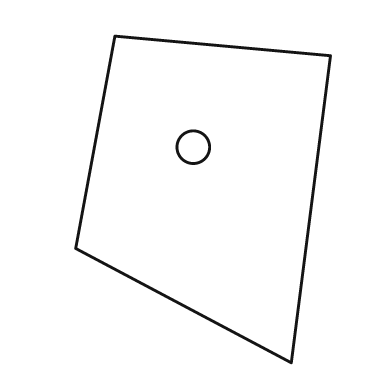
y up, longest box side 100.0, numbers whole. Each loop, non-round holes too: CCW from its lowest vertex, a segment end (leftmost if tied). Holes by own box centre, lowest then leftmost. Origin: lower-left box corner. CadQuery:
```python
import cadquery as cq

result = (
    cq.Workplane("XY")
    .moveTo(66.0, 0.0)
    .lineTo(78.0, 94.0)
    .lineTo(12.0, 100.0)
    .lineTo(0.0, 35.0)
    .close()
    .moveTo(36.0, 66.0)
    .circle(5.0)
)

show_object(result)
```